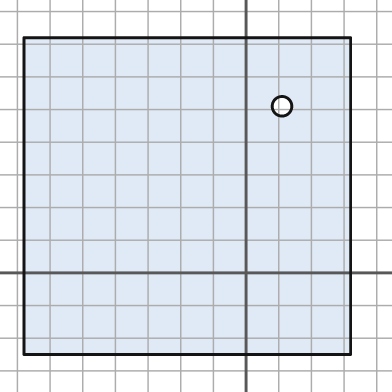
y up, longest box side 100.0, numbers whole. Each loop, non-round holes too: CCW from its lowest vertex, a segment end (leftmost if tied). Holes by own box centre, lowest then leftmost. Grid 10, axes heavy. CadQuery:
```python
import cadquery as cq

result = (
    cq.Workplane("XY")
    .moveTo(-68.0, -25.0)
    .lineTo(32.0, -25.0)
    .lineTo(32.0, 72.0)
    .lineTo(-68.0, 72.0)
    .close()
    .moveTo(11.0, 51.0)
    .circle(3.0)
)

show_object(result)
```